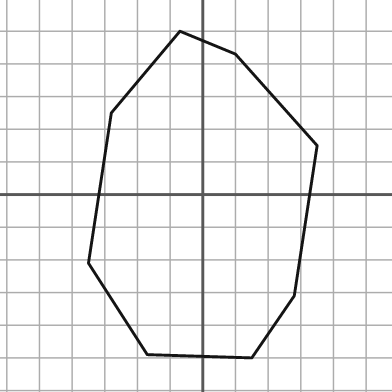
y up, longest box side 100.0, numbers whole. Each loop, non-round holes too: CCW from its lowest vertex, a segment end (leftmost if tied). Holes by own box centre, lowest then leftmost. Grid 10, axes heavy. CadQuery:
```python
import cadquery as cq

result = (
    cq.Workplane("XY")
    .moveTo(15.0, -50.0)
    .lineTo(28.0, -31.0)
    .lineTo(35.0, 15.0)
    .lineTo(10.0, 43.0)
    .lineTo(-7.0, 50.0)
    .lineTo(-28.0, 25.0)
    .lineTo(-35.0, -21.0)
    .lineTo(-17.0, -49.0)
    .close()
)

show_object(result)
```